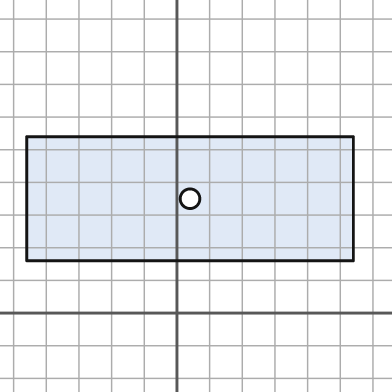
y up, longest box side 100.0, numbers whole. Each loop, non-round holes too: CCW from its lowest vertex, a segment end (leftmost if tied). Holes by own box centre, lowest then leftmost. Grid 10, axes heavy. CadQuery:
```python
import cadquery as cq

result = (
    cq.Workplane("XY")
    .moveTo(-46.0, 16.0)
    .lineTo(54.0, 16.0)
    .lineTo(54.0, 54.0)
    .lineTo(-46.0, 54.0)
    .close()
    .moveTo(4.0, 35.0)
    .circle(3.0)
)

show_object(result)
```